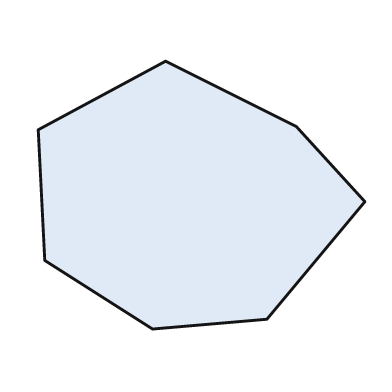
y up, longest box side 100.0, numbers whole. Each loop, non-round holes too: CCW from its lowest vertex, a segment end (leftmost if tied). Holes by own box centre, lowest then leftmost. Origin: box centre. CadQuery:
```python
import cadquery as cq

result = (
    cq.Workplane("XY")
    .moveTo(-15.0, -41.0)
    .lineTo(20.0, -38.0)
    .lineTo(50.0, -2.0)
    .lineTo(29.0, 21.0)
    .lineTo(-11.0, 41.0)
    .lineTo(-50.0, 20.0)
    .lineTo(-48.0, -20.0)
    .close()
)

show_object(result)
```